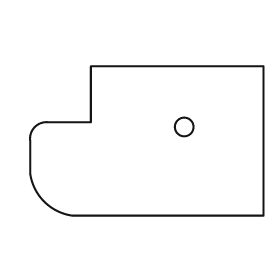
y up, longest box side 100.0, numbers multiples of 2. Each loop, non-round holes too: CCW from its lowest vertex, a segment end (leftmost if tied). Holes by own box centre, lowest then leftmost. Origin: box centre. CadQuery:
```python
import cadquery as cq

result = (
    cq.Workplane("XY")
    .moveTo(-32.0, -32.0)
    .lineTo(50.0, -32.0)
    .lineTo(50.0, 32.0)
    .lineTo(-24.0, 32.0)
    .lineTo(-24.0, 8.0)
    .lineTo(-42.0, 8.0)
    .threePointArc((-48.0, 6.0), (-50.0, 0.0))
    .lineTo(-50.0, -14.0)
    .threePointArc((-44.0, -26.0), (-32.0, -32.0))
    .close()
    .moveTo(16.0, 6.0)
    .circle(4.0)
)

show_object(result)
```